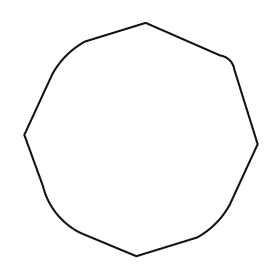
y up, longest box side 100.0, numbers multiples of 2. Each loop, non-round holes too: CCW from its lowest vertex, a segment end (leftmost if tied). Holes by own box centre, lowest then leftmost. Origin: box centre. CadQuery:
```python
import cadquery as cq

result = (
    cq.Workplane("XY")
    .moveTo(-2.0, -50.0)
    .lineTo(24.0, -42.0)
    .threePointArc((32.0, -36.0), (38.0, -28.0))
    .lineTo(50.0, -2.0)
    .lineTo(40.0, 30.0)
    .threePointArc((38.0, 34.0), (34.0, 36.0))
    .lineTo(2.0, 50.0)
    .lineTo(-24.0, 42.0)
    .threePointArc((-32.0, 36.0), (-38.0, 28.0))
    .lineTo(-50.0, 2.0)
    .lineTo(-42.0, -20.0)
    .threePointArc((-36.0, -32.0), (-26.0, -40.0))
    .close()
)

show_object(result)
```